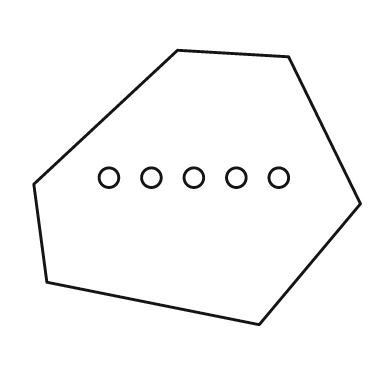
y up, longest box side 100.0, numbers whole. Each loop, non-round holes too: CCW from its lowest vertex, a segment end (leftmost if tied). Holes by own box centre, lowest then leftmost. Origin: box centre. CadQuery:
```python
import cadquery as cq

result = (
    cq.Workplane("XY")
    .moveTo(19.0, -42.0)
    .lineTo(50.0, -5.0)
    .lineTo(28.0, 40.0)
    .lineTo(-6.0, 42.0)
    .lineTo(-50.0, 1.0)
    .lineTo(-46.0, -29.0)
    .close()
    .moveTo(-27.0, 3.0)
    .circle(3.0)
    .moveTo(-14.0, 3.0)
    .circle(3.0)
    .moveTo(-1.0, 3.0)
    .circle(3.0)
    .moveTo(12.0, 3.0)
    .circle(3.0)
    .moveTo(25.0, 3.0)
    .circle(3.0)
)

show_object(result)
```